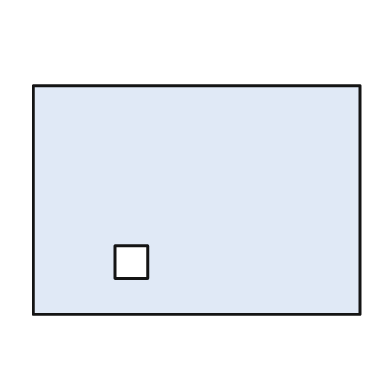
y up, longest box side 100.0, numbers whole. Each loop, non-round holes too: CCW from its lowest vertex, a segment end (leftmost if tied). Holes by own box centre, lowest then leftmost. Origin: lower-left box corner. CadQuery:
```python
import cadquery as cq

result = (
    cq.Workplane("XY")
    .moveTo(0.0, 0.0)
    .lineTo(100.0, 0.0)
    .lineTo(100.0, 70.0)
    .lineTo(0.0, 70.0)
    .close()
    .moveTo(25.0, 11.0)
    .lineTo(35.0, 11.0)
    .lineTo(35.0, 21.0)
    .lineTo(25.0, 21.0)
    .close()
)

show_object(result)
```